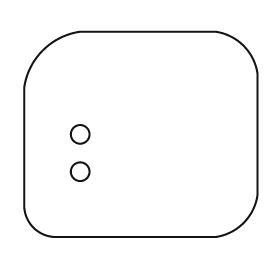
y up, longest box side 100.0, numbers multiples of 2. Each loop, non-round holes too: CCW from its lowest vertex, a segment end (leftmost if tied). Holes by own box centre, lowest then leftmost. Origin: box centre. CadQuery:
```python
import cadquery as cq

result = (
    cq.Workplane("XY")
    .moveTo(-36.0, -44.0)
    .lineTo(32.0, -44.0)
    .threePointArc((44.0, -38.0), (50.0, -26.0))
    .lineTo(50.0, 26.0)
    .threePointArc((44.0, 38.0), (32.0, 44.0))
    .lineTo(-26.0, 44.0)
    .threePointArc((-42.0, 36.0), (-50.0, 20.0))
    .lineTo(-50.0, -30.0)
    .threePointArc((-46.0, -40.0), (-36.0, -44.0))
    .close()
    .moveTo(-26.0, -16.0)
    .circle(4.0)
    .moveTo(-26.0, 0.0)
    .circle(4.0)
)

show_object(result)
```